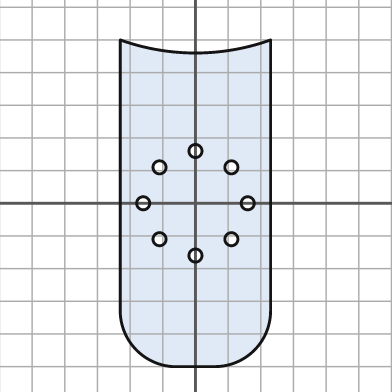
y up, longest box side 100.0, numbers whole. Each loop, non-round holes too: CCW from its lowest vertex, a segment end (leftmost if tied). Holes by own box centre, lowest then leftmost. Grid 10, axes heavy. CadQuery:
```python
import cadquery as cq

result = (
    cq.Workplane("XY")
    .moveTo(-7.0, -50.0)
    .lineTo(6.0, -50.0)
    .threePointArc((18.0, -45.0), (23.0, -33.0))
    .lineTo(23.0, 50.0)
    .threePointArc((0.0, 46.0), (-23.0, 50.0))
    .lineTo(-23.0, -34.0)
    .threePointArc((-18.0, -45.0), (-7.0, -50.0))
    .close()
    .moveTo(0.0, -16.0)
    .circle(2.0)
    .moveTo(-11.0, -11.0)
    .circle(2.0)
    .moveTo(11.0, -11.0)
    .circle(2.0)
    .moveTo(-16.0, 0.0)
    .circle(2.0)
    .moveTo(16.0, 0.0)
    .circle(2.0)
    .moveTo(-11.0, 11.0)
    .circle(2.0)
    .moveTo(11.0, 11.0)
    .circle(2.0)
    .moveTo(0.0, 16.0)
    .circle(2.0)
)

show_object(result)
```